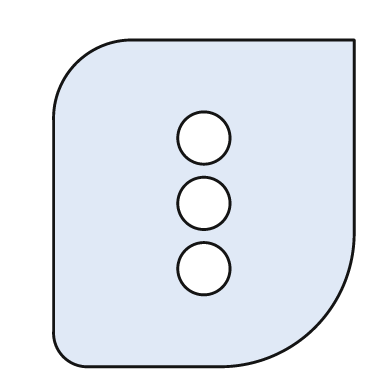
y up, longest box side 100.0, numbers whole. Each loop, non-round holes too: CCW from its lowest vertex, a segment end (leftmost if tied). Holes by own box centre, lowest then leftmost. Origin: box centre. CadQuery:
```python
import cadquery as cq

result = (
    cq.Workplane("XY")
    .moveTo(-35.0, -50.0)
    .lineTo(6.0, -50.0)
    .threePointArc((34.0, -38.0), (46.0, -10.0))
    .lineTo(46.0, 50.0)
    .lineTo(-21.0, 50.0)
    .threePointArc((-39.0, 43.0), (-46.0, 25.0))
    .lineTo(-46.0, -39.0)
    .threePointArc((-43.0, -47.0), (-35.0, -50.0))
    .close()
    .moveTo(0.0, -20.0)
    .circle(8.0)
    .moveTo(0.0, 0.0)
    .circle(8.0)
    .moveTo(0.0, 20.0)
    .circle(8.0)
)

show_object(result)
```